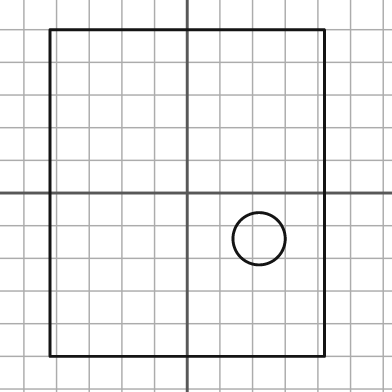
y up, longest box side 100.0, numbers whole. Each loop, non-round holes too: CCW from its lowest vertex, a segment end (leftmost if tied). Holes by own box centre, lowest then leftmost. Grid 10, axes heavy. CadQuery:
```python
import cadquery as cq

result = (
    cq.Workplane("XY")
    .moveTo(-42.0, -50.0)
    .lineTo(42.0, -50.0)
    .lineTo(42.0, 50.0)
    .lineTo(-42.0, 50.0)
    .close()
    .moveTo(22.0, -14.0)
    .circle(8.0)
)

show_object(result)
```